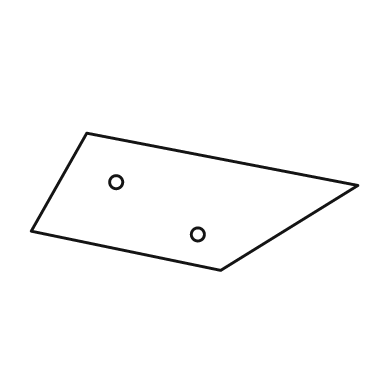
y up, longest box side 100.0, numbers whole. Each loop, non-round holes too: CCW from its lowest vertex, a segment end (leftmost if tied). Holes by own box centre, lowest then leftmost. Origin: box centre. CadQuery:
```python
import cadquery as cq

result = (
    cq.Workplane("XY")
    .moveTo(8.0, -21.0)
    .lineTo(50.0, 5.0)
    .lineTo(-33.0, 21.0)
    .lineTo(-50.0, -9.0)
    .close()
    .moveTo(1.0, -10.0)
    .circle(2.0)
    .moveTo(-24.0, 6.0)
    .circle(2.0)
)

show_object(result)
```